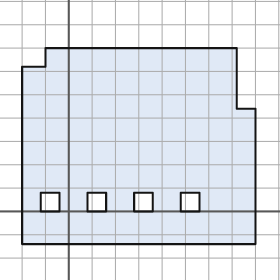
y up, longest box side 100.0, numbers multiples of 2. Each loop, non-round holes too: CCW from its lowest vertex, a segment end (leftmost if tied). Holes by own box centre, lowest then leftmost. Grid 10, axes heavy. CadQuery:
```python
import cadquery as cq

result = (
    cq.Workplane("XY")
    .moveTo(-20.0, -14.0)
    .lineTo(80.0, -14.0)
    .lineTo(80.0, 44.0)
    .lineTo(72.0, 44.0)
    .lineTo(72.0, 70.0)
    .lineTo(-10.0, 70.0)
    .lineTo(-10.0, 62.0)
    .lineTo(-20.0, 62.0)
    .close()
    .moveTo(-12.0, 0.0)
    .lineTo(-4.0, 0.0)
    .lineTo(-4.0, 8.0)
    .lineTo(-12.0, 8.0)
    .close()
    .moveTo(8.0, 0.0)
    .lineTo(16.0, 0.0)
    .lineTo(16.0, 8.0)
    .lineTo(8.0, 8.0)
    .close()
    .moveTo(28.0, 0.0)
    .lineTo(36.0, 0.0)
    .lineTo(36.0, 8.0)
    .lineTo(28.0, 8.0)
    .close()
    .moveTo(48.0, 0.0)
    .lineTo(56.0, 0.0)
    .lineTo(56.0, 8.0)
    .lineTo(48.0, 8.0)
    .close()
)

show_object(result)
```